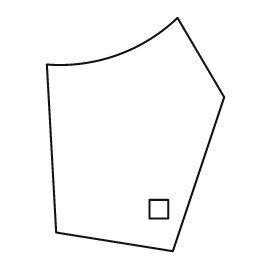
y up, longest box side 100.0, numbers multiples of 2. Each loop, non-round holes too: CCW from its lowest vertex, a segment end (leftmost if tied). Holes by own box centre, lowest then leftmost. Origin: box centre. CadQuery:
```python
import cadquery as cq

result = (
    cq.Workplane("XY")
    .moveTo(16.0, -50.0)
    .lineTo(38.0, 16.0)
    .lineTo(18.0, 50.0)
    .threePointArc((-8.0, 34.0), (-38.0, 30.0))
    .lineTo(-34.0, -42.0)
    .close()
    .moveTo(6.0, -36.0)
    .lineTo(14.0, -36.0)
    .lineTo(14.0, -28.0)
    .lineTo(6.0, -28.0)
    .close()
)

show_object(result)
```